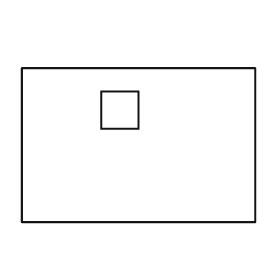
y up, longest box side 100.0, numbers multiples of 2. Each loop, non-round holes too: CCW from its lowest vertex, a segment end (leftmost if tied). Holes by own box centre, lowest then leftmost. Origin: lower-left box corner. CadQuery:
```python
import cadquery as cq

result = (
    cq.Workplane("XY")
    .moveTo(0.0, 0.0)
    .lineTo(100.0, 0.0)
    .lineTo(100.0, 66.0)
    .lineTo(0.0, 66.0)
    .close()
    .moveTo(34.0, 40.0)
    .lineTo(50.0, 40.0)
    .lineTo(50.0, 56.0)
    .lineTo(34.0, 56.0)
    .close()
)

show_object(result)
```